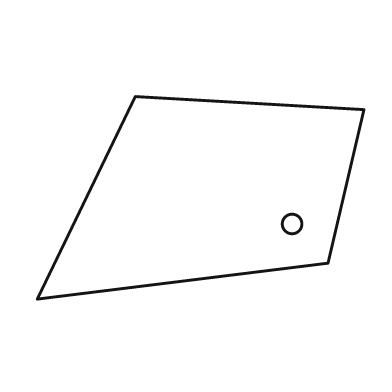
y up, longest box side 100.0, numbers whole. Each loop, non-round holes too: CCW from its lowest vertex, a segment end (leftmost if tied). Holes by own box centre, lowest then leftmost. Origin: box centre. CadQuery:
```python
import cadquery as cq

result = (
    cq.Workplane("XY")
    .moveTo(-50.0, -31.0)
    .lineTo(39.0, -20.0)
    .lineTo(50.0, 27.0)
    .lineTo(-20.0, 31.0)
    .close()
    .moveTo(28.0, -8.0)
    .circle(3.0)
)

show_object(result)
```